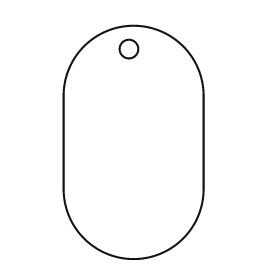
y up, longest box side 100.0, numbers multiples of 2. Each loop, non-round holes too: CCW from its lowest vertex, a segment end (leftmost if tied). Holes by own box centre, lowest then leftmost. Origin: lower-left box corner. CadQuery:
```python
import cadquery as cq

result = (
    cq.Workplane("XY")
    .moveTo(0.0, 30.0)
    .threePointArc((30.0, 0.0), (60.0, 30.0))
    .lineTo(60.0, 70.0)
    .threePointArc((30.0, 100.0), (0.0, 70.0))
    .close()
    .moveTo(28.0, 90.0)
    .circle(4.0)
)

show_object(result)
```